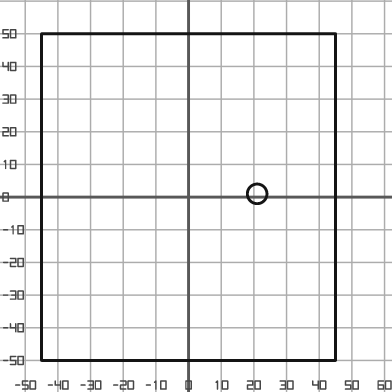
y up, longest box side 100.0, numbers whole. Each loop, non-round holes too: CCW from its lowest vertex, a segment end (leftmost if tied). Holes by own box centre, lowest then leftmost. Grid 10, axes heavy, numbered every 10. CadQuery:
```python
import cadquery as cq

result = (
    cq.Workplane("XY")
    .moveTo(-45.0, -50.0)
    .lineTo(45.0, -50.0)
    .lineTo(45.0, 50.0)
    .lineTo(-45.0, 50.0)
    .close()
    .moveTo(21.0, 1.0)
    .circle(3.0)
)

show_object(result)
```